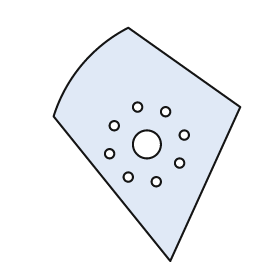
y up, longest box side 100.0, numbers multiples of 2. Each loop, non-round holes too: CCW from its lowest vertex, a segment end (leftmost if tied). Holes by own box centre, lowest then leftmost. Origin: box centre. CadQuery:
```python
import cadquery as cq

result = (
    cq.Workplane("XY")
    .moveTo(10.0, -50.0)
    .lineTo(40.0, 16.0)
    .lineTo(-8.0, 50.0)
    .threePointArc((-28.0, 34.0), (-40.0, 12.0))
    .close()
    .moveTo(4.0, -16.0)
    .circle(2.0)
    .moveTo(-8.0, -14.0)
    .circle(2.0)
    .moveTo(14.0, -8.0)
    .circle(2.0)
    .moveTo(-16.0, -4.0)
    .circle(2.0)
    .moveTo(0.0, 0.0)
    .circle(6.0)
    .moveTo(16.0, 4.0)
    .circle(2.0)
    .moveTo(-14.0, 8.0)
    .circle(2.0)
    .moveTo(8.0, 14.0)
    .circle(2.0)
    .moveTo(-4.0, 16.0)
    .circle(2.0)
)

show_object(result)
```